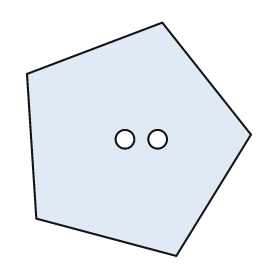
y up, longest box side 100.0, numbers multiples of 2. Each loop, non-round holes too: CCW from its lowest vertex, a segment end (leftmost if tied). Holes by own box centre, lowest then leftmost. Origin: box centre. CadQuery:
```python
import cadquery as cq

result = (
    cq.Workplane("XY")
    .moveTo(16.0, -50.0)
    .lineTo(48.0, 2.0)
    .lineTo(10.0, 50.0)
    .lineTo(-48.0, 28.0)
    .lineTo(-44.0, -34.0)
    .close()
    .moveTo(-6.0, 0.0)
    .circle(4.0)
    .moveTo(8.0, 0.0)
    .circle(4.0)
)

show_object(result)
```